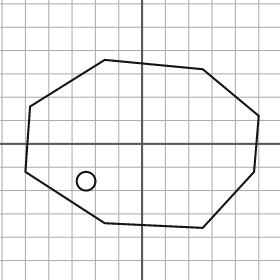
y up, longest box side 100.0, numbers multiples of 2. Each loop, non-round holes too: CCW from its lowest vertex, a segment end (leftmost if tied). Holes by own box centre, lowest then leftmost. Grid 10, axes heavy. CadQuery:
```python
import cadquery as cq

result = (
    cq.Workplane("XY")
    .moveTo(26.0, -36.0)
    .lineTo(48.0, -12.0)
    .lineTo(50.0, 12.0)
    .lineTo(26.0, 32.0)
    .lineTo(-16.0, 36.0)
    .lineTo(-48.0, 16.0)
    .lineTo(-50.0, -12.0)
    .lineTo(-16.0, -34.0)
    .close()
    .moveTo(-24.0, -16.0)
    .circle(4.0)
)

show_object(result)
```